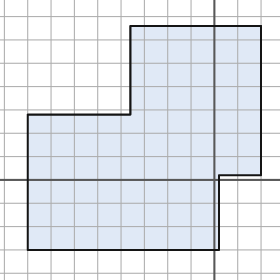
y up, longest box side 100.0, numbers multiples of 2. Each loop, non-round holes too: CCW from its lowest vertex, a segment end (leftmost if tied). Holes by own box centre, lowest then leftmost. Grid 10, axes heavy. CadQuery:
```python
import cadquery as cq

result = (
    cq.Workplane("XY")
    .moveTo(-80.0, -30.0)
    .lineTo(2.0, -30.0)
    .lineTo(2.0, 2.0)
    .lineTo(20.0, 2.0)
    .lineTo(20.0, 66.0)
    .lineTo(-36.0, 66.0)
    .lineTo(-36.0, 28.0)
    .lineTo(-80.0, 28.0)
    .close()
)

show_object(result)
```